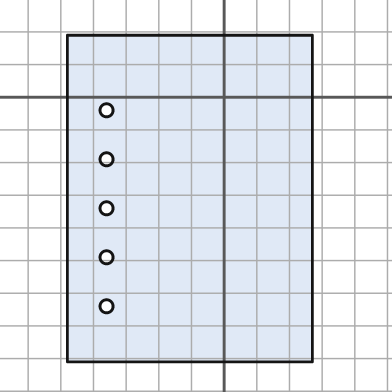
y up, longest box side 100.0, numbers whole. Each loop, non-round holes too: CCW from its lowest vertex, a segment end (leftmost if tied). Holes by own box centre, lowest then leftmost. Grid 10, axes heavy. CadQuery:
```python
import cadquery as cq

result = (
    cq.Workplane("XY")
    .moveTo(-48.0, -81.0)
    .lineTo(27.0, -81.0)
    .lineTo(27.0, 19.0)
    .lineTo(-48.0, 19.0)
    .close()
    .moveTo(-36.0, -64.0)
    .circle(2.0)
    .moveTo(-36.0, -49.0)
    .circle(2.0)
    .moveTo(-36.0, -34.0)
    .circle(2.0)
    .moveTo(-36.0, -19.0)
    .circle(2.0)
    .moveTo(-36.0, -4.0)
    .circle(2.0)
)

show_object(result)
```